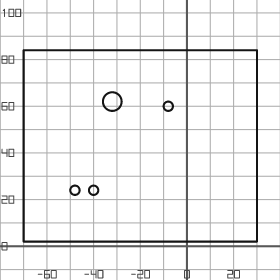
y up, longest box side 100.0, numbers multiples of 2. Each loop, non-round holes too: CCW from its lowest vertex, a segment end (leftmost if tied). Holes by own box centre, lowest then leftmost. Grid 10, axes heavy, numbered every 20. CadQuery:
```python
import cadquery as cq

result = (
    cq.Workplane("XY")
    .moveTo(-70.0, 2.0)
    .lineTo(30.0, 2.0)
    .lineTo(30.0, 84.0)
    .lineTo(-70.0, 84.0)
    .close()
    .moveTo(-48.0, 24.0)
    .circle(2.0)
    .moveTo(-40.0, 24.0)
    .circle(2.0)
    .moveTo(-8.0, 60.0)
    .circle(2.0)
    .moveTo(-32.0, 62.0)
    .circle(4.0)
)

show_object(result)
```